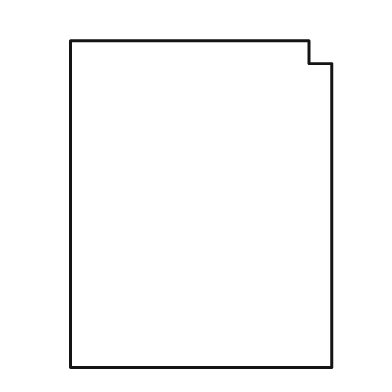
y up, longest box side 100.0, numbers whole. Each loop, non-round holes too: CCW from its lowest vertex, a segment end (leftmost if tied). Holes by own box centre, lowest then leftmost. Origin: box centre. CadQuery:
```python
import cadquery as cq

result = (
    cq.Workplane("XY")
    .moveTo(-40.0, -50.0)
    .lineTo(40.0, -50.0)
    .lineTo(40.0, 43.0)
    .lineTo(33.0, 43.0)
    .lineTo(33.0, 50.0)
    .lineTo(-40.0, 50.0)
    .close()
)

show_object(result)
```